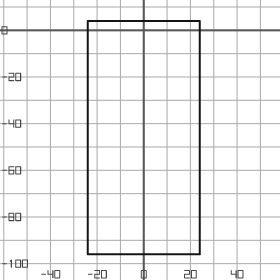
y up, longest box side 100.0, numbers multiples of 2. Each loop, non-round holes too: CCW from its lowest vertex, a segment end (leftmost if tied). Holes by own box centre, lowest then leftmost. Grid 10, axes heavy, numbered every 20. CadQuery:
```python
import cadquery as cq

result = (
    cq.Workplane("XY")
    .moveTo(-24.0, -96.0)
    .lineTo(24.0, -96.0)
    .lineTo(24.0, 4.0)
    .lineTo(-24.0, 4.0)
    .close()
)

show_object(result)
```